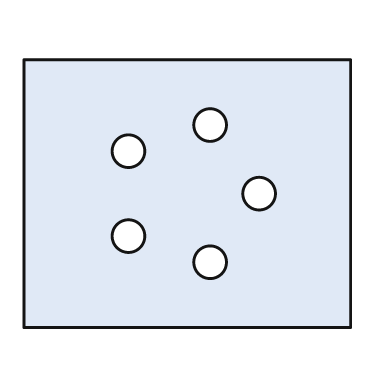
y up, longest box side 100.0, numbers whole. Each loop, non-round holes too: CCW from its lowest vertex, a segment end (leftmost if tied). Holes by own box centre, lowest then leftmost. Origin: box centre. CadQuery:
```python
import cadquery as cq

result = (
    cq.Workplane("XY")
    .moveTo(-50.0, -41.0)
    .lineTo(50.0, -41.0)
    .lineTo(50.0, 41.0)
    .lineTo(-50.0, 41.0)
    .close()
    .moveTo(7.0, -21.0)
    .circle(5.0)
    .moveTo(-18.0, -13.0)
    .circle(5.0)
    .moveTo(22.0, 0.0)
    .circle(5.0)
    .moveTo(-18.0, 13.0)
    .circle(5.0)
    .moveTo(7.0, 21.0)
    .circle(5.0)
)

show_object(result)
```